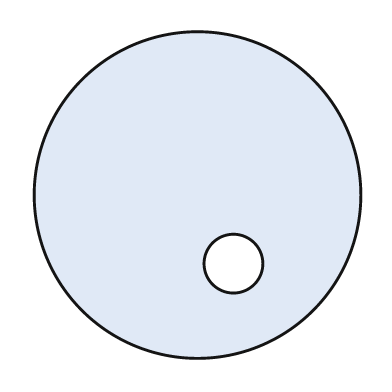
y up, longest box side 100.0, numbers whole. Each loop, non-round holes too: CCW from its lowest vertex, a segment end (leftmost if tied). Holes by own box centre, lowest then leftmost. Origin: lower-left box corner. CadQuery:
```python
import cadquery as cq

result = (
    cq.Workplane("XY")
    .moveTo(50.0, 50.0)
    .circle(50.0)
    .moveTo(61.0, 29.0)
    .circle(9.0)
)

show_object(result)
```